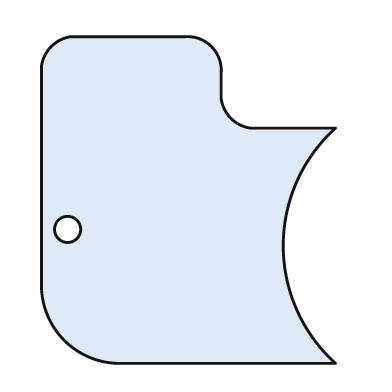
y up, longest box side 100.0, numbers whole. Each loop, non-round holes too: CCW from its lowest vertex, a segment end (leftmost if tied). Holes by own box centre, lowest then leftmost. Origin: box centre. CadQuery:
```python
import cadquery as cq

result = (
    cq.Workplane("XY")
    .moveTo(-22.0, -50.0)
    .lineTo(45.0, -50.0)
    .threePointArc((29.0, -14.0), (45.0, 22.0))
    .lineTo(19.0, 22.0)
    .threePointArc((13.0, 25.0), (10.0, 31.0))
    .lineTo(10.0, 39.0)
    .threePointArc((7.0, 47.0), (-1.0, 50.0))
    .lineTo(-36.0, 50.0)
    .threePointArc((-42.0, 47.0), (-45.0, 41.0))
    .lineTo(-45.0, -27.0)
    .threePointArc((-38.0, -43.0), (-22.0, -50.0))
    .close()
    .moveTo(-37.0, -9.0)
    .circle(4.0)
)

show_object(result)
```